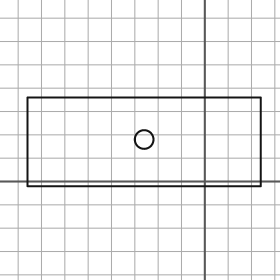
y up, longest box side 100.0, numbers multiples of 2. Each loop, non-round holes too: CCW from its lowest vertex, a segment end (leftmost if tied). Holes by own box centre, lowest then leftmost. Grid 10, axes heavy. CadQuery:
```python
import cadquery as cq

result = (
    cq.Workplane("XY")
    .moveTo(-76.0, -2.0)
    .lineTo(24.0, -2.0)
    .lineTo(24.0, 36.0)
    .lineTo(-76.0, 36.0)
    .close()
    .moveTo(-26.0, 18.0)
    .circle(4.0)
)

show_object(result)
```